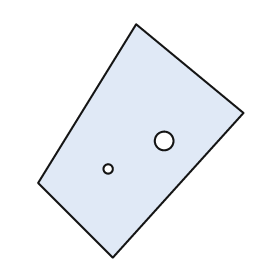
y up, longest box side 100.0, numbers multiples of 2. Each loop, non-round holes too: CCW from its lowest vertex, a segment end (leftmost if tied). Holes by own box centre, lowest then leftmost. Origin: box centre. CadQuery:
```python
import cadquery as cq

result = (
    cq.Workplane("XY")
    .moveTo(-12.0, -50.0)
    .lineTo(44.0, 12.0)
    .lineTo(-2.0, 50.0)
    .lineTo(-44.0, -18.0)
    .close()
    .moveTo(-14.0, -12.0)
    .circle(2.0)
    .moveTo(10.0, 0.0)
    .circle(4.0)
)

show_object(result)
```